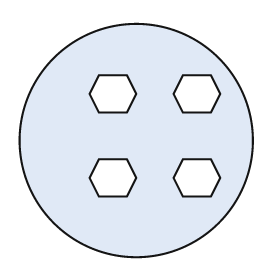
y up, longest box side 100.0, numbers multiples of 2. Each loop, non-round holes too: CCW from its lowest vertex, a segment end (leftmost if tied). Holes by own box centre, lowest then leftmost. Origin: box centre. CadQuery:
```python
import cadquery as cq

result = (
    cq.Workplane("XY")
    .moveTo(0.0, 0.0)
    .circle(50.0)
    .moveTo(-16.0, -24.0)
    .lineTo(-4.0, -24.0)
    .lineTo(0.0, -16.0)
    .lineTo(-4.0, -8.0)
    .lineTo(-16.0, -8.0)
    .lineTo(-20.0, -16.0)
    .close()
    .moveTo(20.0, -24.0)
    .lineTo(32.0, -24.0)
    .lineTo(36.0, -16.0)
    .lineTo(32.0, -8.0)
    .lineTo(20.0, -8.0)
    .lineTo(16.0, -16.0)
    .close()
    .moveTo(-16.0, 12.0)
    .lineTo(-4.0, 12.0)
    .lineTo(0.0, 20.0)
    .lineTo(-4.0, 28.0)
    .lineTo(-16.0, 28.0)
    .lineTo(-20.0, 20.0)
    .close()
    .moveTo(20.0, 12.0)
    .lineTo(32.0, 12.0)
    .lineTo(36.0, 20.0)
    .lineTo(32.0, 28.0)
    .lineTo(20.0, 28.0)
    .lineTo(16.0, 20.0)
    .close()
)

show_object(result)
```